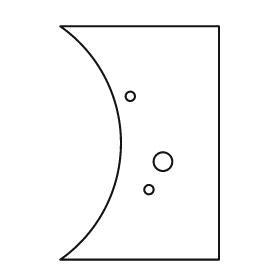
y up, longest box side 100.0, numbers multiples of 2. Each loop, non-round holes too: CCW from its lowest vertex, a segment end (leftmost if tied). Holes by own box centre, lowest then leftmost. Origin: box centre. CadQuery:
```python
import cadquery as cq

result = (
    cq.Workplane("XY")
    .moveTo(-34.0, -50.0)
    .lineTo(34.0, -50.0)
    .lineTo(34.0, 50.0)
    .lineTo(-34.0, 50.0)
    .threePointArc((-8.0, 0.0), (-34.0, -50.0))
    .close()
    .moveTo(4.0, -20.0)
    .circle(2.0)
    .moveTo(10.0, -8.0)
    .circle(4.0)
    .moveTo(-4.0, 20.0)
    .circle(2.0)
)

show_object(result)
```